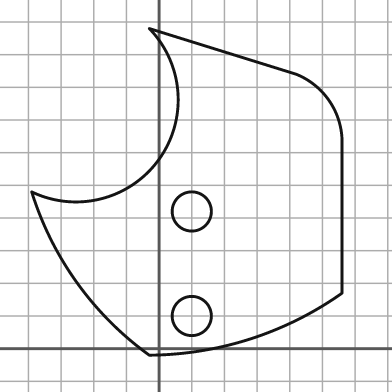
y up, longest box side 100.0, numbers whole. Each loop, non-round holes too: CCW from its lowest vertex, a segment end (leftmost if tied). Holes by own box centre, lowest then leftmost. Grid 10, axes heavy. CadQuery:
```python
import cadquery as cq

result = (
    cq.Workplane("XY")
    .moveTo(-3.0, -2.0)
    .threePointArc((28.0, 3.0), (56.0, 17.0))
    .lineTo(56.0, 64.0)
    .threePointArc((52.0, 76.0), (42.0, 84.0))
    .lineTo(-3.0, 98.0)
    .threePointArc((0.0, 58.0), (-39.0, 48.0))
    .threePointArc((-25.0, 20.0), (-3.0, -2.0))
    .close()
    .moveTo(10.0, 10.0)
    .circle(6.0)
    .moveTo(10.0, 42.0)
    .circle(6.0)
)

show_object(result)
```